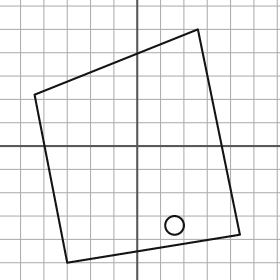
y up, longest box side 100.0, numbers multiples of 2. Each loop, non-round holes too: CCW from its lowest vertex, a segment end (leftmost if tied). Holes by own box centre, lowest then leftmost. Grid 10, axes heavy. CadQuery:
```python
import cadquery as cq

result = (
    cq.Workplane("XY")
    .moveTo(-30.0, -50.0)
    .lineTo(44.0, -38.0)
    .lineTo(26.0, 50.0)
    .lineTo(-44.0, 22.0)
    .close()
    .moveTo(16.0, -34.0)
    .circle(4.0)
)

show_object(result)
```